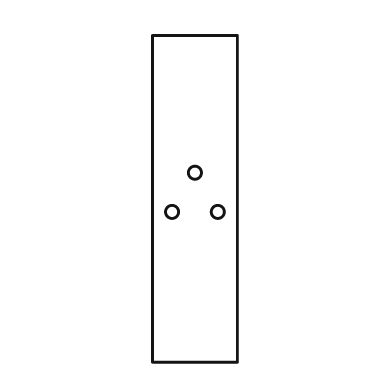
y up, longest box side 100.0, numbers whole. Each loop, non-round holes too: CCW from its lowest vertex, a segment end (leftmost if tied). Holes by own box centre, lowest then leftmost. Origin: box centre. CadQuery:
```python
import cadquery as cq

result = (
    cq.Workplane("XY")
    .moveTo(-13.0, -50.0)
    .lineTo(13.0, -50.0)
    .lineTo(13.0, 50.0)
    .lineTo(-13.0, 50.0)
    .close()
    .moveTo(-7.0, -4.0)
    .circle(2.0)
    .moveTo(7.0, -4.0)
    .circle(2.0)
    .moveTo(0.0, 8.0)
    .circle(2.0)
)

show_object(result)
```